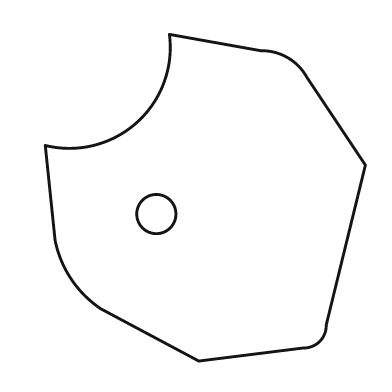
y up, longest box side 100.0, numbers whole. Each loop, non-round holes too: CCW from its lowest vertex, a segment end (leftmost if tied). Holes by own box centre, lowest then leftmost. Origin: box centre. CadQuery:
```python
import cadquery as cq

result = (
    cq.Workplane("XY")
    .moveTo(-2.0, -50.0)
    .lineTo(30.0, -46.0)
    .threePointArc((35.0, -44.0), (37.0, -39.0))
    .lineTo(49.0, 10.0)
    .lineTo(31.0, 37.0)
    .threePointArc((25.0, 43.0), (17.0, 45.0))
    .lineTo(-11.0, 50.0)
    .threePointArc((-21.0, 23.0), (-49.0, 16.0))
    .lineTo(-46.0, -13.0)
    .threePointArc((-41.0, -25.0), (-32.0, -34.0))
    .close()
    .moveTo(-15.0, -5.0)
    .circle(6.0)
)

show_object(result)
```